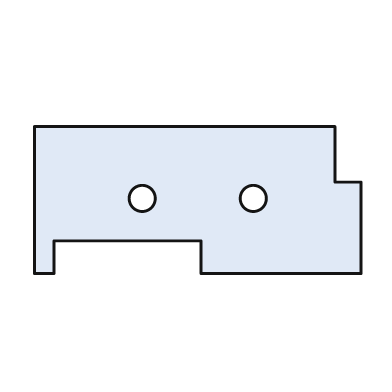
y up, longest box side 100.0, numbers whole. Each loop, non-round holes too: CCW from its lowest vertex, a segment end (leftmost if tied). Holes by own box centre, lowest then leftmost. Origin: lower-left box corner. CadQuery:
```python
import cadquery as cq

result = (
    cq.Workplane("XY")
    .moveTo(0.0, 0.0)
    .lineTo(6.0, 0.0)
    .lineTo(6.0, 10.0)
    .lineTo(51.0, 10.0)
    .lineTo(51.0, 0.0)
    .lineTo(100.0, 0.0)
    .lineTo(100.0, 28.0)
    .lineTo(92.0, 28.0)
    .lineTo(92.0, 45.0)
    .lineTo(0.0, 45.0)
    .close()
    .moveTo(33.0, 23.0)
    .circle(4.0)
    .moveTo(67.0, 23.0)
    .circle(4.0)
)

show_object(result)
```